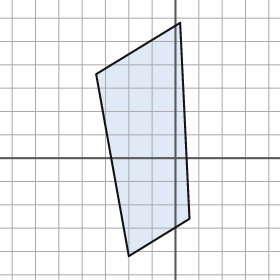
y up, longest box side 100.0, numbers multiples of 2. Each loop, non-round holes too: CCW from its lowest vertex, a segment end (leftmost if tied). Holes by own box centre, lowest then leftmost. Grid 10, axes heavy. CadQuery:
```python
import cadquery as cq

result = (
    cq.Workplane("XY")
    .moveTo(-20.0, -42.0)
    .lineTo(6.0, -26.0)
    .lineTo(2.0, 58.0)
    .lineTo(-34.0, 36.0)
    .close()
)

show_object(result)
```